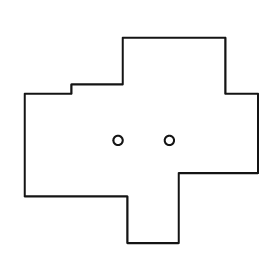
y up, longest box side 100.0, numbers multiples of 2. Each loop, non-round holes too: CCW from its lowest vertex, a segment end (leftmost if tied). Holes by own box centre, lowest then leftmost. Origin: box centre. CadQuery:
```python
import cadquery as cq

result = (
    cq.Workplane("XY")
    .moveTo(-6.0, -44.0)
    .lineTo(16.0, -44.0)
    .lineTo(16.0, -14.0)
    .lineTo(50.0, -14.0)
    .lineTo(50.0, 20.0)
    .lineTo(36.0, 20.0)
    .lineTo(36.0, 44.0)
    .lineTo(-8.0, 44.0)
    .lineTo(-8.0, 24.0)
    .lineTo(-30.0, 24.0)
    .lineTo(-30.0, 20.0)
    .lineTo(-50.0, 20.0)
    .lineTo(-50.0, -24.0)
    .lineTo(-6.0, -24.0)
    .close()
    .moveTo(-10.0, 0.0)
    .circle(2.0)
    .moveTo(12.0, 0.0)
    .circle(2.0)
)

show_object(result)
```